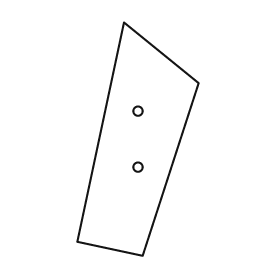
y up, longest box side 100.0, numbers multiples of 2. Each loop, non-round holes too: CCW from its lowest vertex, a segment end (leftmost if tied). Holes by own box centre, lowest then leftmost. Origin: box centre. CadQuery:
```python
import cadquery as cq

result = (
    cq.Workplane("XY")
    .moveTo(2.0, -50.0)
    .lineTo(26.0, 24.0)
    .lineTo(-6.0, 50.0)
    .lineTo(-26.0, -44.0)
    .close()
    .moveTo(0.0, -12.0)
    .circle(2.0)
    .moveTo(0.0, 12.0)
    .circle(2.0)
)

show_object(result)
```